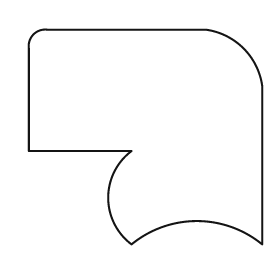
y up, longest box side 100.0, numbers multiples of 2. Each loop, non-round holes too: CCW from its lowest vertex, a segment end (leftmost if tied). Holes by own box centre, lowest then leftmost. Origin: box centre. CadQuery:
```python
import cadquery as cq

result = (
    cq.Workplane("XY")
    .moveTo(-6.0, -46.0)
    .threePointArc((22.0, -36.0), (50.0, -46.0))
    .lineTo(50.0, 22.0)
    .threePointArc((42.0, 38.0), (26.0, 46.0))
    .lineTo(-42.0, 46.0)
    .threePointArc((-48.0, 44.0), (-50.0, 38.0))
    .lineTo(-50.0, -6.0)
    .lineTo(-6.0, -6.0)
    .threePointArc((-16.0, -26.0), (-6.0, -46.0))
    .close()
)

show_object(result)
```